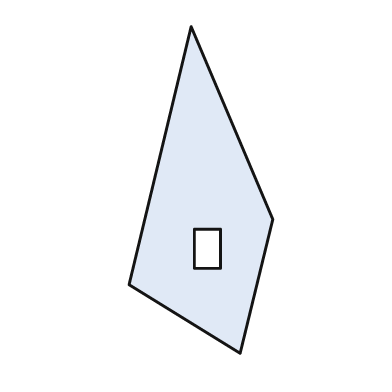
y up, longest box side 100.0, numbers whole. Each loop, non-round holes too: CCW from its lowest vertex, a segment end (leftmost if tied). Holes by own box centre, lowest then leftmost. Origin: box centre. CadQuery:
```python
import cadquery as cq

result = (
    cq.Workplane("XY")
    .moveTo(12.0, -50.0)
    .lineTo(22.0, -9.0)
    .lineTo(-3.0, 50.0)
    .lineTo(-22.0, -29.0)
    .close()
    .moveTo(-2.0, -24.0)
    .lineTo(6.0, -24.0)
    .lineTo(6.0, -12.0)
    .lineTo(-2.0, -12.0)
    .close()
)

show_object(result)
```